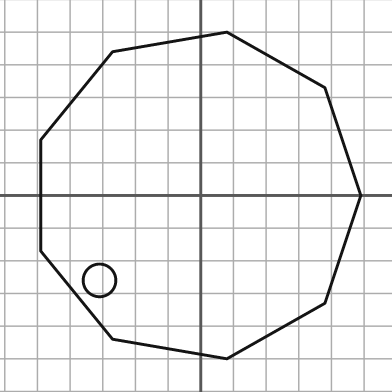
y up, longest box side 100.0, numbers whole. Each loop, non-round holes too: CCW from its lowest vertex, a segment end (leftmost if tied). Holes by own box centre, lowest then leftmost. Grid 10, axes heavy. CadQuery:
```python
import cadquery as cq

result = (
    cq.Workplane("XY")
    .moveTo(8.0, -50.0)
    .lineTo(38.0, -33.0)
    .lineTo(49.0, 0.0)
    .lineTo(38.0, 33.0)
    .lineTo(8.0, 50.0)
    .lineTo(-27.0, 44.0)
    .lineTo(-49.0, 17.0)
    .lineTo(-49.0, -17.0)
    .lineTo(-27.0, -44.0)
    .close()
    .moveTo(-31.0, -26.0)
    .circle(5.0)
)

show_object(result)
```